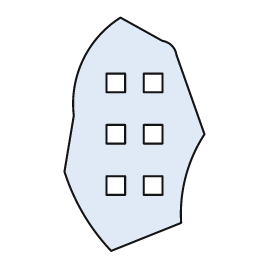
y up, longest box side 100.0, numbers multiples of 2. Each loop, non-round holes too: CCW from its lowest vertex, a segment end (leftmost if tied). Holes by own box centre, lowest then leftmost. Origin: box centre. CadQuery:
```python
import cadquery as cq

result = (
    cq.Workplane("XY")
    .moveTo(-10.0, -50.0)
    .lineTo(20.0, -38.0)
    .threePointArc((22.0, -18.0), (30.0, 0.0))
    .lineTo(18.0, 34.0)
    .threePointArc((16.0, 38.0), (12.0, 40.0))
    .lineTo(-6.0, 50.0)
    .threePointArc((-22.0, 32.0), (-26.0, 8.0))
    .lineTo(-30.0, -16.0)
    .threePointArc((-22.0, -34.0), (-10.0, -50.0))
    .close()
    .moveTo(-12.0, -26.0)
    .lineTo(-4.0, -26.0)
    .lineTo(-4.0, -18.0)
    .lineTo(-12.0, -18.0)
    .close()
    .moveTo(4.0, -26.0)
    .lineTo(12.0, -26.0)
    .lineTo(12.0, -18.0)
    .lineTo(4.0, -18.0)
    .close()
    .moveTo(-12.0, -4.0)
    .lineTo(-4.0, -4.0)
    .lineTo(-4.0, 4.0)
    .lineTo(-12.0, 4.0)
    .close()
    .moveTo(4.0, -4.0)
    .lineTo(12.0, -4.0)
    .lineTo(12.0, 4.0)
    .lineTo(4.0, 4.0)
    .close()
    .moveTo(-12.0, 18.0)
    .lineTo(-4.0, 18.0)
    .lineTo(-4.0, 26.0)
    .lineTo(-12.0, 26.0)
    .close()
    .moveTo(4.0, 18.0)
    .lineTo(12.0, 18.0)
    .lineTo(12.0, 26.0)
    .lineTo(4.0, 26.0)
    .close()
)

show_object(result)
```